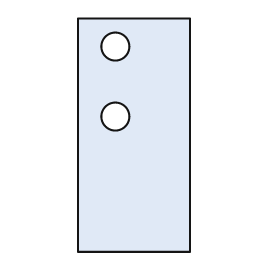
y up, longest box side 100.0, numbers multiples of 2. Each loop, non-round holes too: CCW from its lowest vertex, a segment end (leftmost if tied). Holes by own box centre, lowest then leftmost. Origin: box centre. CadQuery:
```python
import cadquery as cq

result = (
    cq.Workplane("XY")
    .moveTo(-24.0, -50.0)
    .lineTo(24.0, -50.0)
    .lineTo(24.0, 50.0)
    .lineTo(-24.0, 50.0)
    .close()
    .moveTo(-8.0, 8.0)
    .circle(6.0)
    .moveTo(-8.0, 38.0)
    .circle(6.0)
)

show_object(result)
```